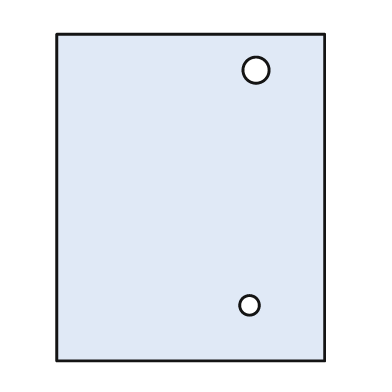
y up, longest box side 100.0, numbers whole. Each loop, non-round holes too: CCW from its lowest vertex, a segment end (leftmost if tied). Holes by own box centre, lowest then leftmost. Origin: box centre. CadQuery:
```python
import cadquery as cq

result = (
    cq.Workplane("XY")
    .moveTo(-41.0, -50.0)
    .lineTo(41.0, -50.0)
    .lineTo(41.0, 50.0)
    .lineTo(-41.0, 50.0)
    .close()
    .moveTo(18.0, -33.0)
    .circle(3.0)
    .moveTo(20.0, 39.0)
    .circle(4.0)
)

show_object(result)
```